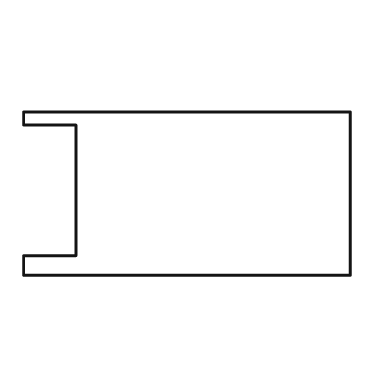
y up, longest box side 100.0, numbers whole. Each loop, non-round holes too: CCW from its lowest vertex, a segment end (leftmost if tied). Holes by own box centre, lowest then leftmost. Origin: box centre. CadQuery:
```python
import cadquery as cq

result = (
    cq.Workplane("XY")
    .moveTo(-50.0, -25.0)
    .lineTo(50.0, -25.0)
    .lineTo(50.0, 25.0)
    .lineTo(-50.0, 25.0)
    .lineTo(-50.0, 21.0)
    .lineTo(-34.0, 21.0)
    .lineTo(-34.0, -19.0)
    .lineTo(-50.0, -19.0)
    .close()
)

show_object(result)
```